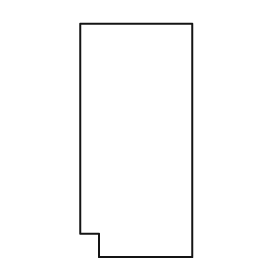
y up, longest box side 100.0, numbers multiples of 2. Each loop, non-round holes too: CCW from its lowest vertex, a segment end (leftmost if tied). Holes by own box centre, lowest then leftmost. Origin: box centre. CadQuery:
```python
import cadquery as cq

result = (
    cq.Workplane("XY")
    .moveTo(-16.0, -50.0)
    .lineTo(24.0, -50.0)
    .lineTo(24.0, 50.0)
    .lineTo(-24.0, 50.0)
    .lineTo(-24.0, -40.0)
    .lineTo(-16.0, -40.0)
    .close()
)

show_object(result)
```